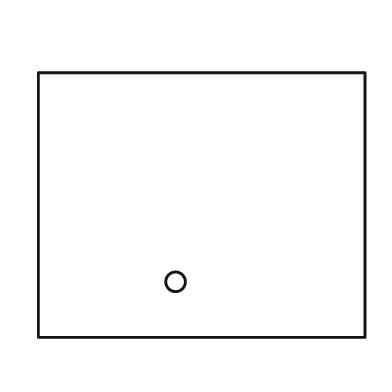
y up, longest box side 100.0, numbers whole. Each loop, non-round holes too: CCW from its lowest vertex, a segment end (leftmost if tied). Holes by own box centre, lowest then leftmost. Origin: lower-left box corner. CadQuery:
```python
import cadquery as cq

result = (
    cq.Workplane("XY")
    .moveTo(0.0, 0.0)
    .lineTo(100.0, 0.0)
    .lineTo(100.0, 81.0)
    .lineTo(0.0, 81.0)
    .close()
    .moveTo(42.0, 17.0)
    .circle(3.0)
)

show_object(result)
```